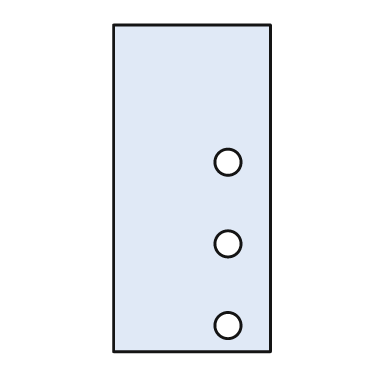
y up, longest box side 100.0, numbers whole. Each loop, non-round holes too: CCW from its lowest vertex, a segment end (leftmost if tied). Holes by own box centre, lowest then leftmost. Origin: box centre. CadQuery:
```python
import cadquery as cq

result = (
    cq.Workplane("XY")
    .moveTo(-24.0, -50.0)
    .lineTo(24.0, -50.0)
    .lineTo(24.0, 50.0)
    .lineTo(-24.0, 50.0)
    .close()
    .moveTo(11.0, -42.0)
    .circle(4.0)
    .moveTo(11.0, -17.0)
    .circle(4.0)
    .moveTo(11.0, 8.0)
    .circle(4.0)
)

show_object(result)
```